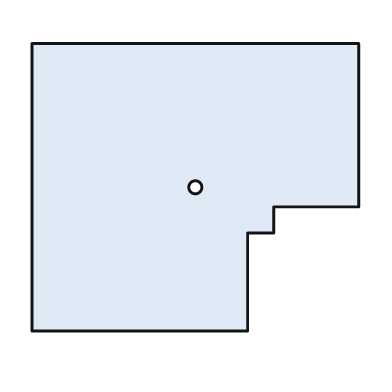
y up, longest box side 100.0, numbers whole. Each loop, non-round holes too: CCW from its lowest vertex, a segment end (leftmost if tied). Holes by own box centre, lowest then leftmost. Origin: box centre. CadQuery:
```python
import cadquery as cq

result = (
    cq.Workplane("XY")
    .moveTo(-50.0, -44.0)
    .lineTo(16.0, -44.0)
    .lineTo(16.0, -14.0)
    .lineTo(24.0, -14.0)
    .lineTo(24.0, -6.0)
    .lineTo(50.0, -6.0)
    .lineTo(50.0, 44.0)
    .lineTo(-50.0, 44.0)
    .close()
    .moveTo(0.0, 0.0)
    .circle(2.0)
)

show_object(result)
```